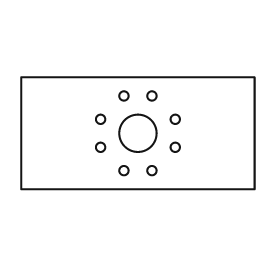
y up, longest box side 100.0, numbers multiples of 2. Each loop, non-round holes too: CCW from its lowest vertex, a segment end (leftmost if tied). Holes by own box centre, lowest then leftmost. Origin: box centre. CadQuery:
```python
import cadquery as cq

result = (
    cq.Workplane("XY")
    .moveTo(-50.0, -24.0)
    .lineTo(50.0, -24.0)
    .lineTo(50.0, 24.0)
    .lineTo(-50.0, 24.0)
    .close()
    .moveTo(-6.0, -16.0)
    .circle(2.0)
    .moveTo(6.0, -16.0)
    .circle(2.0)
    .moveTo(-16.0, -6.0)
    .circle(2.0)
    .moveTo(16.0, -6.0)
    .circle(2.0)
    .moveTo(0.0, 0.0)
    .circle(8.0)
    .moveTo(-16.0, 6.0)
    .circle(2.0)
    .moveTo(16.0, 6.0)
    .circle(2.0)
    .moveTo(-6.0, 16.0)
    .circle(2.0)
    .moveTo(6.0, 16.0)
    .circle(2.0)
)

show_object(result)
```